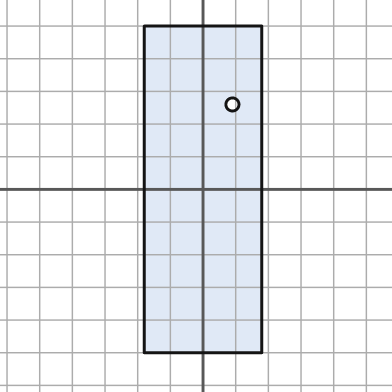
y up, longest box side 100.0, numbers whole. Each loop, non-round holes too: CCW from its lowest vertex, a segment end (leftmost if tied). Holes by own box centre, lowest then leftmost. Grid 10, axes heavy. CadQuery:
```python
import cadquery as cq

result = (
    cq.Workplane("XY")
    .moveTo(-18.0, -50.0)
    .lineTo(18.0, -50.0)
    .lineTo(18.0, 50.0)
    .lineTo(-18.0, 50.0)
    .close()
    .moveTo(9.0, 26.0)
    .circle(2.0)
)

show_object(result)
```